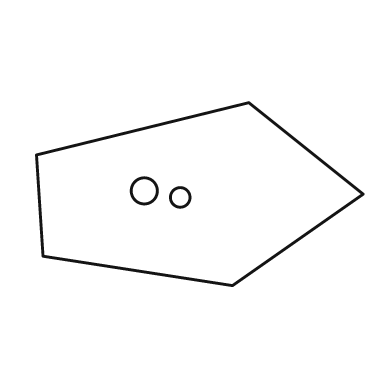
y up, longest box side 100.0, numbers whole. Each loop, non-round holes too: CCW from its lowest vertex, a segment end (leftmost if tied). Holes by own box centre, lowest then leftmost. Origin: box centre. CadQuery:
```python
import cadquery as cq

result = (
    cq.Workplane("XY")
    .moveTo(10.0, -28.0)
    .lineTo(50.0, 0.0)
    .lineTo(15.0, 28.0)
    .lineTo(-50.0, 12.0)
    .lineTo(-48.0, -19.0)
    .close()
    .moveTo(-6.0, -1.0)
    .circle(3.0)
    .moveTo(-17.0, 1.0)
    .circle(4.0)
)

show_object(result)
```